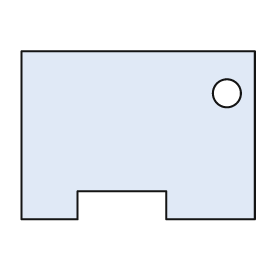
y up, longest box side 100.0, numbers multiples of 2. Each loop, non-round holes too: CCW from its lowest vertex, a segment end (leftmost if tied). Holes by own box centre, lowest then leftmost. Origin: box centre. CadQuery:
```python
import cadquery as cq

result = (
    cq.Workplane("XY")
    .moveTo(-50.0, -36.0)
    .lineTo(-26.0, -36.0)
    .lineTo(-26.0, -24.0)
    .lineTo(12.0, -24.0)
    .lineTo(12.0, -36.0)
    .lineTo(50.0, -36.0)
    .lineTo(50.0, 36.0)
    .lineTo(-50.0, 36.0)
    .close()
    .moveTo(38.0, 18.0)
    .circle(6.0)
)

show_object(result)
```